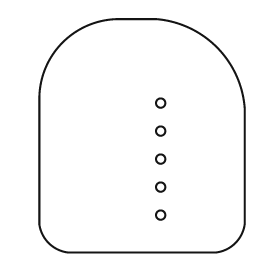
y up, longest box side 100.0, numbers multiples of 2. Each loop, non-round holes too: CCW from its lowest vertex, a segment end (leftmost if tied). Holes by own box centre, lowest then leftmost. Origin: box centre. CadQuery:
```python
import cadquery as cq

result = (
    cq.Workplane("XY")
    .moveTo(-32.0, -50.0)
    .lineTo(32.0, -50.0)
    .threePointArc((40.0, -46.0), (44.0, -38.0))
    .lineTo(44.0, 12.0)
    .threePointArc((32.0, 38.0), (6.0, 50.0))
    .lineTo(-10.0, 50.0)
    .threePointArc((-34.0, 40.0), (-44.0, 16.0))
    .lineTo(-44.0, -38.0)
    .threePointArc((-40.0, -46.0), (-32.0, -50.0))
    .close()
    .moveTo(8.0, -34.0)
    .circle(2.0)
    .moveTo(8.0, -22.0)
    .circle(2.0)
    .moveTo(8.0, -10.0)
    .circle(2.0)
    .moveTo(8.0, 2.0)
    .circle(2.0)
    .moveTo(8.0, 14.0)
    .circle(2.0)
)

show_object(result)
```